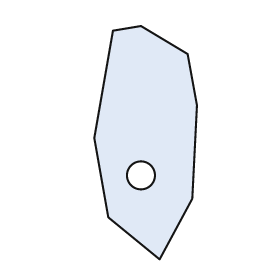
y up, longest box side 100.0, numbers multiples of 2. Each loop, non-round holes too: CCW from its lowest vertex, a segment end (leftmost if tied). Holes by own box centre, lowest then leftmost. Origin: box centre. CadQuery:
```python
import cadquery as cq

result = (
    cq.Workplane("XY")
    .moveTo(6.0, -50.0)
    .lineTo(20.0, -24.0)
    .lineTo(22.0, 16.0)
    .lineTo(18.0, 38.0)
    .lineTo(-2.0, 50.0)
    .lineTo(-14.0, 48.0)
    .lineTo(-22.0, 2.0)
    .lineTo(-16.0, -32.0)
    .close()
    .moveTo(-2.0, -14.0)
    .circle(6.0)
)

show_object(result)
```